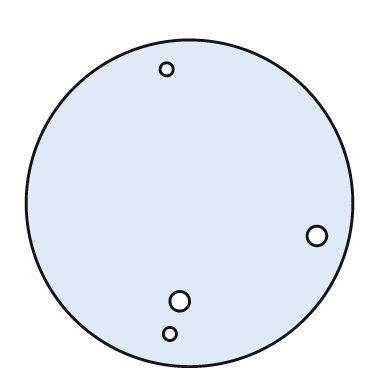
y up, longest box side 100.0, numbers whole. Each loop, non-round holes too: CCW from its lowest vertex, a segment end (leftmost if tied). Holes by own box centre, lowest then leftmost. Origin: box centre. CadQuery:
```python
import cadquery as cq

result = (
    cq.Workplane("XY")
    .moveTo(0.0, 0.0)
    .circle(50.0)
    .moveTo(-6.0, -40.0)
    .circle(2.0)
    .moveTo(-3.0, -30.0)
    .circle(3.0)
    .moveTo(39.0, -10.0)
    .circle(3.0)
    .moveTo(-7.0, 41.0)
    .circle(2.0)
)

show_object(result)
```